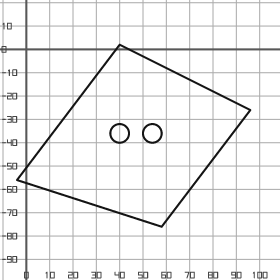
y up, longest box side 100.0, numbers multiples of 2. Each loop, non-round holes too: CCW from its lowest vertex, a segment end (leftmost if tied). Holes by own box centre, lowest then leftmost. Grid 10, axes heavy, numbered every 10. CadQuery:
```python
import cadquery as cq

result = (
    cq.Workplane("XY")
    .moveTo(58.0, -76.0)
    .lineTo(96.0, -26.0)
    .lineTo(40.0, 2.0)
    .lineTo(-4.0, -56.0)
    .close()
    .moveTo(40.0, -36.0)
    .circle(4.0)
    .moveTo(54.0, -36.0)
    .circle(4.0)
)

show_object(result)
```